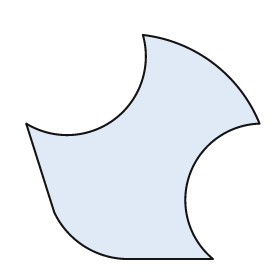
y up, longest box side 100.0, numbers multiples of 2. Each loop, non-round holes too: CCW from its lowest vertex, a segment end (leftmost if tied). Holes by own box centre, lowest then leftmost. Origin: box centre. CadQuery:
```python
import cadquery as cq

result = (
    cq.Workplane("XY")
    .moveTo(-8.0, -48.0)
    .lineTo(30.0, -48.0)
    .threePointArc((20.0, -12.0), (50.0, 10.0))
    .threePointArc((30.0, 36.0), (0.0, 48.0))
    .threePointArc((-12.0, 12.0), (-50.0, 10.0))
    .lineTo(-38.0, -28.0)
    .threePointArc((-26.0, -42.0), (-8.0, -48.0))
    .close()
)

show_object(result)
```